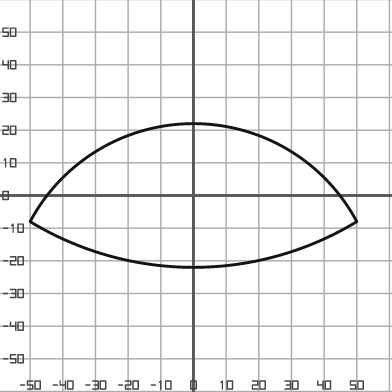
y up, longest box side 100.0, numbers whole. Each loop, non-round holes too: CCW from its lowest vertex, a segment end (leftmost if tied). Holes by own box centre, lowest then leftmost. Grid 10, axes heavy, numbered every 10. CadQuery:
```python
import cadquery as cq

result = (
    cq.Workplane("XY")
    .moveTo(-50.0, -8.0)
    .threePointArc((0.0, -22.0), (50.0, -8.0))
    .threePointArc((0.0, 22.0), (-50.0, -8.0))
    .close()
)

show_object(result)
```